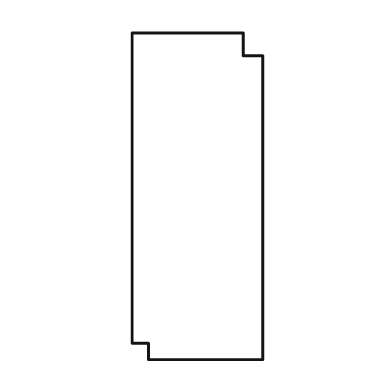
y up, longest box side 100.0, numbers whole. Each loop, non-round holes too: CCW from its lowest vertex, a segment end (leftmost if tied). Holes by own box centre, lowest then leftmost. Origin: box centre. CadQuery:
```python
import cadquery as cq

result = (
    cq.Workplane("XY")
    .moveTo(-15.0, -50.0)
    .lineTo(20.0, -50.0)
    .lineTo(20.0, 43.0)
    .lineTo(14.0, 43.0)
    .lineTo(14.0, 50.0)
    .lineTo(-20.0, 50.0)
    .lineTo(-20.0, -45.0)
    .lineTo(-15.0, -45.0)
    .close()
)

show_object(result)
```